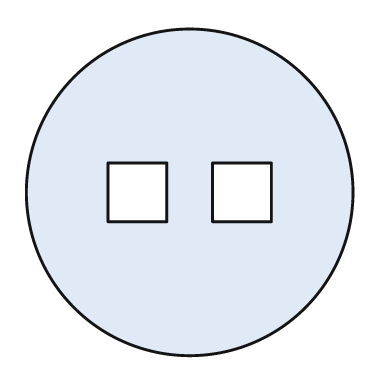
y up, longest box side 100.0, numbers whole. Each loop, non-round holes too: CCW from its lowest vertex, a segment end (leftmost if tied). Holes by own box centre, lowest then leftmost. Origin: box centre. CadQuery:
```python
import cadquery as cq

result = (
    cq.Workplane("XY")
    .moveTo(0.0, 0.0)
    .circle(50.0)
    .moveTo(-25.0, -9.0)
    .lineTo(-7.0, -9.0)
    .lineTo(-7.0, 9.0)
    .lineTo(-25.0, 9.0)
    .close()
    .moveTo(7.0, -9.0)
    .lineTo(25.0, -9.0)
    .lineTo(25.0, 9.0)
    .lineTo(7.0, 9.0)
    .close()
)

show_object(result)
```